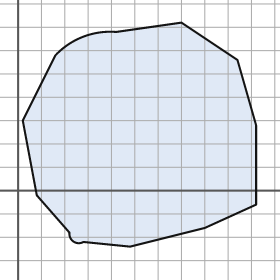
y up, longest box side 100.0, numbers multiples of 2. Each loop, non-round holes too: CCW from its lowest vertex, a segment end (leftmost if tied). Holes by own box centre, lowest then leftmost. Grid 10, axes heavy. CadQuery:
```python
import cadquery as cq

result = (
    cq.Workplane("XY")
    .moveTo(48.0, -24.0)
    .lineTo(80.0, -16.0)
    .lineTo(102.0, -6.0)
    .lineTo(102.0, 28.0)
    .lineTo(94.0, 56.0)
    .lineTo(70.0, 72.0)
    .lineTo(42.0, 68.0)
    .threePointArc((28.0, 66.0), (16.0, 58.0))
    .lineTo(2.0, 30.0)
    .lineTo(8.0, -2.0)
    .lineTo(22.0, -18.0)
    .threePointArc((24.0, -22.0), (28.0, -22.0))
    .close()
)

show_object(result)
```